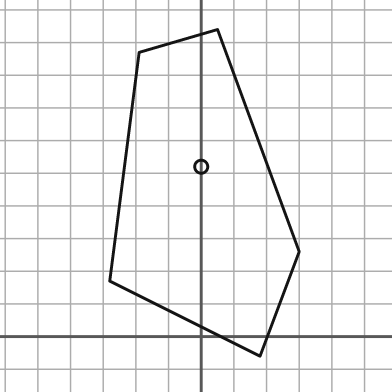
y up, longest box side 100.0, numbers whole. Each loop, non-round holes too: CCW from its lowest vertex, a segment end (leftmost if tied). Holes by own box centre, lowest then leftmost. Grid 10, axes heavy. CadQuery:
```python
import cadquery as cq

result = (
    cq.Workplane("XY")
    .moveTo(18.0, -6.0)
    .lineTo(30.0, 26.0)
    .lineTo(5.0, 94.0)
    .lineTo(-19.0, 87.0)
    .lineTo(-28.0, 17.0)
    .close()
    .moveTo(0.0, 52.0)
    .circle(2.0)
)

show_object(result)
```